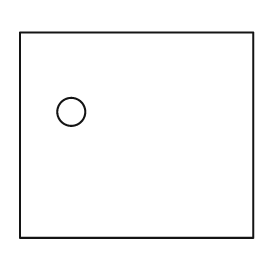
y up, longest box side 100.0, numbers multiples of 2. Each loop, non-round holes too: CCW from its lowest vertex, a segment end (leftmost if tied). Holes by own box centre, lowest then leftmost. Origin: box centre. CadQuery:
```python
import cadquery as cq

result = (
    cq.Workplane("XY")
    .moveTo(-50.0, -44.0)
    .lineTo(50.0, -44.0)
    .lineTo(50.0, 44.0)
    .lineTo(-50.0, 44.0)
    .close()
    .moveTo(-28.0, 10.0)
    .circle(6.0)
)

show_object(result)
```